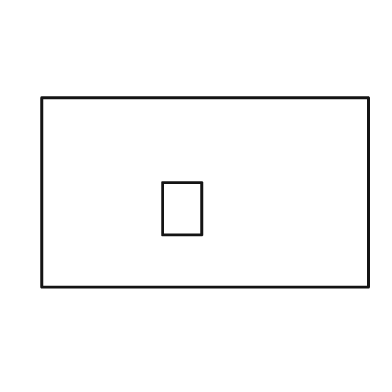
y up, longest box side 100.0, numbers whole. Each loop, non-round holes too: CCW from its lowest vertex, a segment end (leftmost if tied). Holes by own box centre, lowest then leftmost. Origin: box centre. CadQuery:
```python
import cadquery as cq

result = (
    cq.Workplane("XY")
    .moveTo(-50.0, -29.0)
    .lineTo(50.0, -29.0)
    .lineTo(50.0, 29.0)
    .lineTo(-50.0, 29.0)
    .close()
    .moveTo(-13.0, -13.0)
    .lineTo(-1.0, -13.0)
    .lineTo(-1.0, 3.0)
    .lineTo(-13.0, 3.0)
    .close()
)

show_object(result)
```